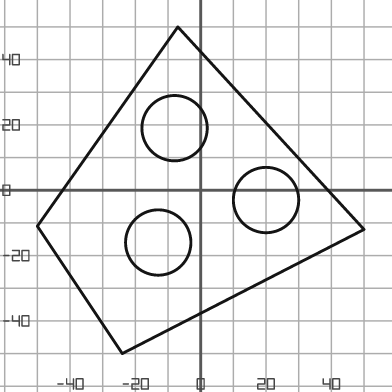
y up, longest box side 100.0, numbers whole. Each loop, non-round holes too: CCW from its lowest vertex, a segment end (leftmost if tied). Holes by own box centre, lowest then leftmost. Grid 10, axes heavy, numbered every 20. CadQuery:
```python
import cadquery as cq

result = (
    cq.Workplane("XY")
    .moveTo(-24.0, -50.0)
    .lineTo(50.0, -12.0)
    .lineTo(-7.0, 50.0)
    .lineTo(-50.0, -11.0)
    .close()
    .moveTo(-13.0, -16.0)
    .circle(10.0)
    .moveTo(20.0, -3.0)
    .circle(10.0)
    .moveTo(-8.0, 19.0)
    .circle(10.0)
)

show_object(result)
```